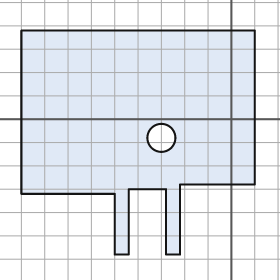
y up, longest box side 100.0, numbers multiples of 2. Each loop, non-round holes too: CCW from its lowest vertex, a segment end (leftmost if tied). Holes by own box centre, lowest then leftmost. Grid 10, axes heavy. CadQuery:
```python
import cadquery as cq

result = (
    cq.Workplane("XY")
    .moveTo(-50.0, -58.0)
    .lineTo(-44.0, -58.0)
    .lineTo(-44.0, -30.0)
    .lineTo(-28.0, -30.0)
    .lineTo(-28.0, -58.0)
    .lineTo(-22.0, -58.0)
    .lineTo(-22.0, -28.0)
    .lineTo(10.0, -28.0)
    .lineTo(10.0, 38.0)
    .lineTo(-90.0, 38.0)
    .lineTo(-90.0, -32.0)
    .lineTo(-50.0, -32.0)
    .close()
    .moveTo(-30.0, -8.0)
    .circle(6.0)
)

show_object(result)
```